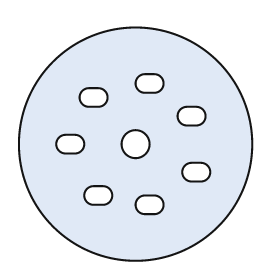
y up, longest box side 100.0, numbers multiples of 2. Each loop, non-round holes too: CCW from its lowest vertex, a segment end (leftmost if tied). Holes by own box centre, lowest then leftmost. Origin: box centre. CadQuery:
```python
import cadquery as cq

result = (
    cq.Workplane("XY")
    .moveTo(0.0, 0.0)
    .circle(50.0)
    .moveTo(4.0, -30.0)
    .lineTo(8.0, -30.0)
    .threePointArc((12.0, -26.0), (8.0, -22.0))
    .lineTo(4.0, -22.0)
    .threePointArc((0.0, -26.0), (4.0, -30.0))
    .close()
    .moveTo(-18.0, -26.0)
    .lineTo(-14.0, -26.0)
    .threePointArc((-10.0, -22.0), (-14.0, -18.0))
    .lineTo(-18.0, -18.0)
    .threePointArc((-22.0, -22.0), (-18.0, -26.0))
    .close()
    .moveTo(24.0, -16.0)
    .lineTo(28.0, -16.0)
    .threePointArc((32.0, -12.0), (28.0, -8.0))
    .lineTo(24.0, -8.0)
    .threePointArc((20.0, -12.0), (24.0, -16.0))
    .close()
    .moveTo(-30.0, -4.0)
    .lineTo(-26.0, -4.0)
    .threePointArc((-22.0, 0.0), (-26.0, 4.0))
    .lineTo(-30.0, 4.0)
    .threePointArc((-34.0, 0.0), (-30.0, -4.0))
    .close()
    .moveTo(0.0, 0.0)
    .circle(6.0)
    .moveTo(22.0, 8.0)
    .lineTo(26.0, 8.0)
    .threePointArc((30.0, 12.0), (26.0, 16.0))
    .lineTo(22.0, 16.0)
    .threePointArc((18.0, 12.0), (22.0, 8.0))
    .close()
    .moveTo(-20.0, 16.0)
    .lineTo(-16.0, 16.0)
    .threePointArc((-12.0, 20.0), (-16.0, 24.0))
    .lineTo(-20.0, 24.0)
    .threePointArc((-24.0, 20.0), (-20.0, 16.0))
    .close()
    .moveTo(4.0, 22.0)
    .lineTo(8.0, 22.0)
    .threePointArc((12.0, 26.0), (8.0, 30.0))
    .lineTo(4.0, 30.0)
    .threePointArc((0.0, 26.0), (4.0, 22.0))
    .close()
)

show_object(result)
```